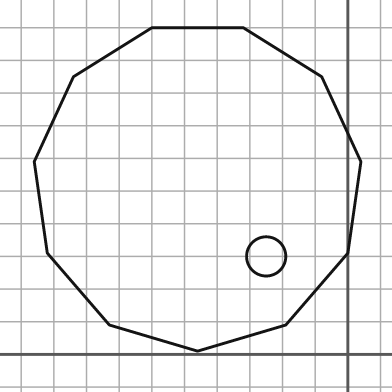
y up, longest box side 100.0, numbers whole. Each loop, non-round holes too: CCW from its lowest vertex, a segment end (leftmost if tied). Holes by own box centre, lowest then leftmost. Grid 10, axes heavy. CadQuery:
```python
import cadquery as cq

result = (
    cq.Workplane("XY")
    .moveTo(-46.0, 1.0)
    .lineTo(-19.0, 9.0)
    .lineTo(0.0, 31.0)
    .lineTo(4.0, 59.0)
    .lineTo(-8.0, 85.0)
    .lineTo(-32.0, 100.0)
    .lineTo(-60.0, 100.0)
    .lineTo(-84.0, 85.0)
    .lineTo(-96.0, 59.0)
    .lineTo(-92.0, 31.0)
    .lineTo(-73.0, 9.0)
    .close()
    .moveTo(-25.0, 30.0)
    .circle(6.0)
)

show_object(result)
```